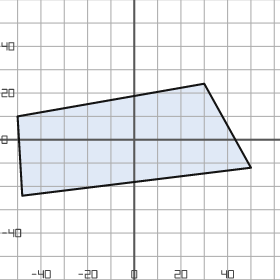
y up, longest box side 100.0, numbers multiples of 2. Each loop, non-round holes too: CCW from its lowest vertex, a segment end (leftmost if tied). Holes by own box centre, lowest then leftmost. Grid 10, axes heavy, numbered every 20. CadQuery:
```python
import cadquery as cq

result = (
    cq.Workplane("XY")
    .moveTo(-48.0, -24.0)
    .lineTo(50.0, -12.0)
    .lineTo(30.0, 24.0)
    .lineTo(-50.0, 10.0)
    .close()
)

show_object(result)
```